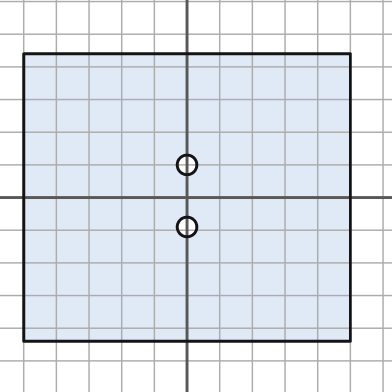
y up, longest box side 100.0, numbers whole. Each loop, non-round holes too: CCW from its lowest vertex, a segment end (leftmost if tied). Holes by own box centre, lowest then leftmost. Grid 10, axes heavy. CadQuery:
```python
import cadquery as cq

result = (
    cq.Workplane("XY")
    .moveTo(-50.0, -44.0)
    .lineTo(50.0, -44.0)
    .lineTo(50.0, 44.0)
    .lineTo(-50.0, 44.0)
    .close()
    .moveTo(0.0, -9.0)
    .circle(3.0)
    .moveTo(0.0, 10.0)
    .circle(3.0)
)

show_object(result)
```